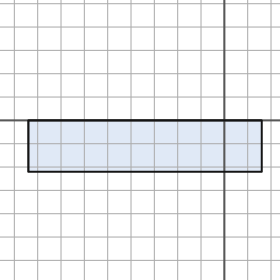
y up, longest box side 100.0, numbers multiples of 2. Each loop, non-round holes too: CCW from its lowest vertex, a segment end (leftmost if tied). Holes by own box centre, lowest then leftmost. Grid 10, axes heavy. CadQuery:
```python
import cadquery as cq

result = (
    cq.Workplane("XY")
    .moveTo(-84.0, -22.0)
    .lineTo(16.0, -22.0)
    .lineTo(16.0, 0.0)
    .lineTo(-84.0, 0.0)
    .close()
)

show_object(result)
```